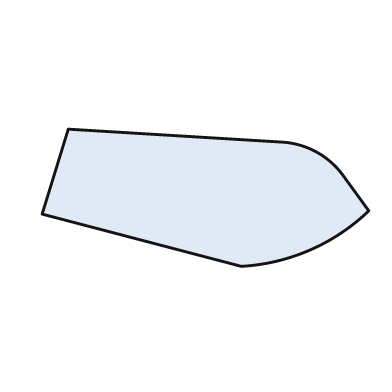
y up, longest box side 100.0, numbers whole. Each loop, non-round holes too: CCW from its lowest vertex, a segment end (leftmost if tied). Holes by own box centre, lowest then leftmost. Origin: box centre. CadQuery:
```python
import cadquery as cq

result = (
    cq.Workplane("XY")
    .moveTo(11.0, -21.0)
    .threePointArc((32.0, -16.0), (50.0, -4.0))
    .lineTo(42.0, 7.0)
    .threePointArc((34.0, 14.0), (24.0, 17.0))
    .lineTo(-42.0, 21.0)
    .lineTo(-50.0, -5.0)
    .close()
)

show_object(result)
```